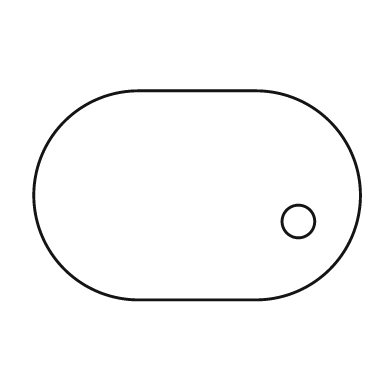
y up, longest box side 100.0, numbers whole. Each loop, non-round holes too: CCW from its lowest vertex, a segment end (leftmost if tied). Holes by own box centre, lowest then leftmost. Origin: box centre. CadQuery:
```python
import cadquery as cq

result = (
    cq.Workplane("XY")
    .moveTo(-18.0, -32.0)
    .lineTo(18.0, -32.0)
    .threePointArc((50.0, 0.0), (18.0, 32.0))
    .lineTo(-18.0, 32.0)
    .threePointArc((-50.0, 0.0), (-18.0, -32.0))
    .close()
    .moveTo(31.0, -8.0)
    .circle(5.0)
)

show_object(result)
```